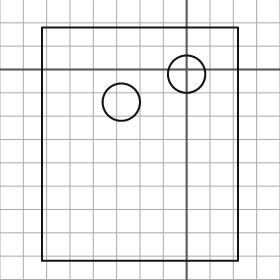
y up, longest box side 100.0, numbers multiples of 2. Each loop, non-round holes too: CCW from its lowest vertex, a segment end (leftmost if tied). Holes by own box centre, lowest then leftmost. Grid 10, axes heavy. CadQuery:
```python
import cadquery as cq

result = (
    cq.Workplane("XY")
    .moveTo(-62.0, -82.0)
    .lineTo(22.0, -82.0)
    .lineTo(22.0, 18.0)
    .lineTo(-62.0, 18.0)
    .close()
    .moveTo(-28.0, -14.0)
    .circle(8.0)
    .moveTo(0.0, -2.0)
    .circle(8.0)
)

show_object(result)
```